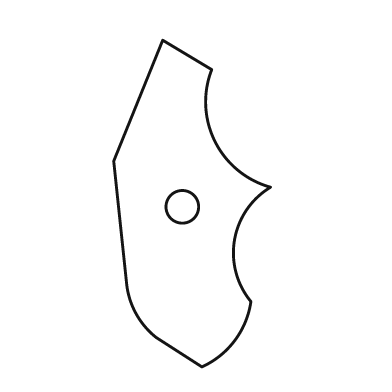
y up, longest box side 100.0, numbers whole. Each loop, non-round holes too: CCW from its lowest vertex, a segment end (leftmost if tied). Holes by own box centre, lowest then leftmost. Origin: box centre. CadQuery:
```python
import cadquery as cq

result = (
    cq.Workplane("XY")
    .moveTo(3.0, -50.0)
    .threePointArc((13.0, -42.0), (18.0, -30.0))
    .threePointArc((13.0, -11.0), (24.0, 5.0))
    .threePointArc((7.0, 19.0), (6.0, 41.0))
    .lineTo(-9.0, 50.0)
    .lineTo(-24.0, 13.0)
    .lineTo(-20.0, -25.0)
    .threePointArc((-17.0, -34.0), (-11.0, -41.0))
    .close()
    .moveTo(-3.0, -1.0)
    .circle(5.0)
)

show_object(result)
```